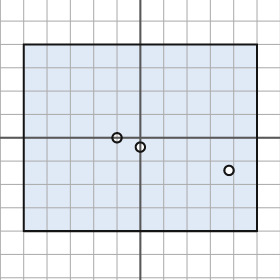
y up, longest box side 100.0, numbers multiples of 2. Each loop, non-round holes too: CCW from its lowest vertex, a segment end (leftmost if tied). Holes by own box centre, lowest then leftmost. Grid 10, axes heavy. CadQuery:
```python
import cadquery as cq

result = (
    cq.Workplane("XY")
    .moveTo(-50.0, -40.0)
    .lineTo(50.0, -40.0)
    .lineTo(50.0, 40.0)
    .lineTo(-50.0, 40.0)
    .close()
    .moveTo(38.0, -14.0)
    .circle(2.0)
    .moveTo(0.0, -4.0)
    .circle(2.0)
    .moveTo(-10.0, 0.0)
    .circle(2.0)
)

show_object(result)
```